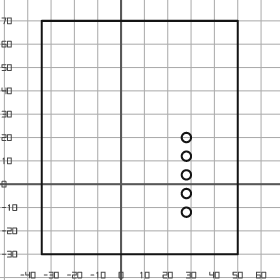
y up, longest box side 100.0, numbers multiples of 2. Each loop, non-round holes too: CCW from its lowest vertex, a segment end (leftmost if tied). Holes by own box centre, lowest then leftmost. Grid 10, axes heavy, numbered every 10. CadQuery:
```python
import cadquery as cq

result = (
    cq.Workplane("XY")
    .moveTo(-34.0, -30.0)
    .lineTo(50.0, -30.0)
    .lineTo(50.0, 70.0)
    .lineTo(-34.0, 70.0)
    .close()
    .moveTo(28.0, -12.0)
    .circle(2.0)
    .moveTo(28.0, -4.0)
    .circle(2.0)
    .moveTo(28.0, 4.0)
    .circle(2.0)
    .moveTo(28.0, 12.0)
    .circle(2.0)
    .moveTo(28.0, 20.0)
    .circle(2.0)
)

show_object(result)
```